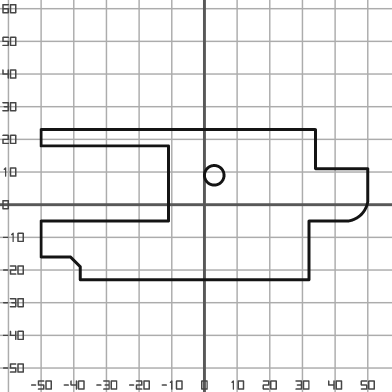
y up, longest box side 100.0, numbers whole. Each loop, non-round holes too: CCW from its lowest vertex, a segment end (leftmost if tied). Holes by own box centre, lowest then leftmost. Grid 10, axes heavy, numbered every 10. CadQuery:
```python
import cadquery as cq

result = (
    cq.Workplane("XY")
    .moveTo(-38.0, -23.0)
    .lineTo(32.0, -23.0)
    .lineTo(32.0, -5.0)
    .lineTo(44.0, -5.0)
    .threePointArc((48.0, -3.0), (50.0, 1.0))
    .lineTo(50.0, 11.0)
    .lineTo(34.0, 11.0)
    .lineTo(34.0, 23.0)
    .lineTo(-50.0, 23.0)
    .lineTo(-50.0, 18.0)
    .lineTo(-11.0, 18.0)
    .lineTo(-11.0, -5.0)
    .lineTo(-50.0, -5.0)
    .lineTo(-50.0, -16.0)
    .lineTo(-41.0, -16.0)
    .lineTo(-38.0, -19.0)
    .close()
    .moveTo(3.0, 9.0)
    .circle(3.0)
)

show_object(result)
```